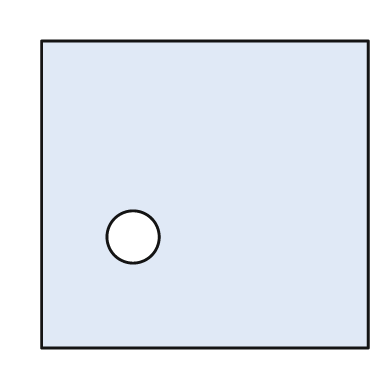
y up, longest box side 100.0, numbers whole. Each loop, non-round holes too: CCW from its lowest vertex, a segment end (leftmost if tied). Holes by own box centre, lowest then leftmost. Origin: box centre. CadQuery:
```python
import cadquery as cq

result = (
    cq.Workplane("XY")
    .moveTo(-50.0, -47.0)
    .lineTo(50.0, -47.0)
    .lineTo(50.0, 47.0)
    .lineTo(-50.0, 47.0)
    .close()
    .moveTo(-22.0, -13.0)
    .circle(8.0)
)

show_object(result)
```